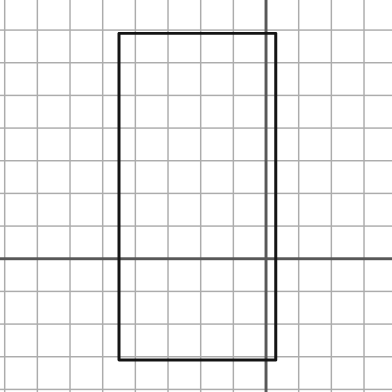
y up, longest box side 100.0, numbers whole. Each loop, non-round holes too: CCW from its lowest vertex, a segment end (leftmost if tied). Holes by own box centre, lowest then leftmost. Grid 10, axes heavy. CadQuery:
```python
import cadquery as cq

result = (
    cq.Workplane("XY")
    .moveTo(-45.0, -31.0)
    .lineTo(3.0, -31.0)
    .lineTo(3.0, 69.0)
    .lineTo(-45.0, 69.0)
    .close()
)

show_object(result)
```